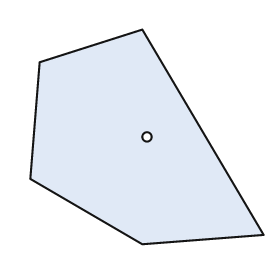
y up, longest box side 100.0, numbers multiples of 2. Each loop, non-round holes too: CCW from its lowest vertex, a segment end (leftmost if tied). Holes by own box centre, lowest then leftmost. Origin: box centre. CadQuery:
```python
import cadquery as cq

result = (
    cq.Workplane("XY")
    .moveTo(-2.0, -46.0)
    .lineTo(50.0, -42.0)
    .lineTo(-2.0, 46.0)
    .lineTo(-46.0, 32.0)
    .lineTo(-50.0, -18.0)
    .close()
    .moveTo(0.0, 0.0)
    .circle(2.0)
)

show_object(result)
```